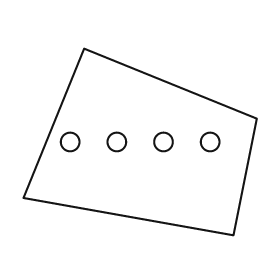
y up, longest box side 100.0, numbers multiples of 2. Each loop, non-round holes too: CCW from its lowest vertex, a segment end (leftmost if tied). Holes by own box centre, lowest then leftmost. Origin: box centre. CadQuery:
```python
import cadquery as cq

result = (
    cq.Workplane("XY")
    .moveTo(40.0, -40.0)
    .lineTo(50.0, 10.0)
    .lineTo(-24.0, 40.0)
    .lineTo(-50.0, -24.0)
    .close()
    .moveTo(-30.0, 0.0)
    .circle(4.0)
    .moveTo(-10.0, 0.0)
    .circle(4.0)
    .moveTo(10.0, 0.0)
    .circle(4.0)
    .moveTo(30.0, 0.0)
    .circle(4.0)
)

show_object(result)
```